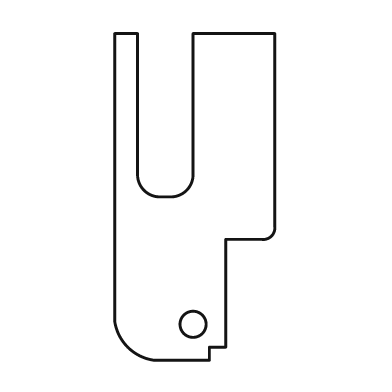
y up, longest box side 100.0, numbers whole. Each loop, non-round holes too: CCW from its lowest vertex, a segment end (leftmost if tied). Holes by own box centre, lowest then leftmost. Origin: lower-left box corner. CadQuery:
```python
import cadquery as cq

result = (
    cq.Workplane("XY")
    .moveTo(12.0, 0.0)
    .lineTo(29.0, 0.0)
    .lineTo(29.0, 4.0)
    .lineTo(34.0, 4.0)
    .lineTo(34.0, 37.0)
    .lineTo(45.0, 37.0)
    .threePointArc((48.0, 38.0), (49.0, 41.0))
    .lineTo(49.0, 100.0)
    .lineTo(24.0, 100.0)
    .lineTo(24.0, 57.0)
    .threePointArc((22.0, 52.0), (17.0, 50.0))
    .lineTo(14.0, 50.0)
    .threePointArc((9.0, 52.0), (7.0, 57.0))
    .lineTo(7.0, 100.0)
    .lineTo(0.0, 100.0)
    .lineTo(0.0, 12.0)
    .threePointArc((4.0, 4.0), (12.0, 0.0))
    .close()
    .moveTo(24.0, 11.0)
    .circle(4.0)
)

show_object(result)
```